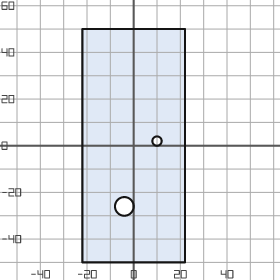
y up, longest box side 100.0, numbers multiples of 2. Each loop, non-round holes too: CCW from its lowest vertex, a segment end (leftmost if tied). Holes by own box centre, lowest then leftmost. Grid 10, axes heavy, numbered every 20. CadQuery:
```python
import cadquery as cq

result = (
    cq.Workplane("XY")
    .moveTo(-22.0, -50.0)
    .lineTo(22.0, -50.0)
    .lineTo(22.0, 50.0)
    .lineTo(-22.0, 50.0)
    .close()
    .moveTo(-4.0, -26.0)
    .circle(4.0)
    .moveTo(10.0, 2.0)
    .circle(2.0)
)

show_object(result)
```